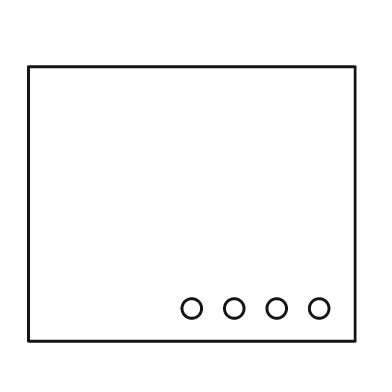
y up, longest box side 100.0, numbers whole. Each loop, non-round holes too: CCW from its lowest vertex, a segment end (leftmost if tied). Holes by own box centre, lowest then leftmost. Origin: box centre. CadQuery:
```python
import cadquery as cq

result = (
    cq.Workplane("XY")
    .moveTo(-50.0, -42.0)
    .lineTo(50.0, -42.0)
    .lineTo(50.0, 42.0)
    .lineTo(-50.0, 42.0)
    .close()
    .moveTo(0.0, -32.0)
    .circle(3.0)
    .moveTo(13.0, -32.0)
    .circle(3.0)
    .moveTo(26.0, -32.0)
    .circle(3.0)
    .moveTo(39.0, -32.0)
    .circle(3.0)
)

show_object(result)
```